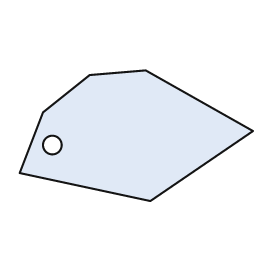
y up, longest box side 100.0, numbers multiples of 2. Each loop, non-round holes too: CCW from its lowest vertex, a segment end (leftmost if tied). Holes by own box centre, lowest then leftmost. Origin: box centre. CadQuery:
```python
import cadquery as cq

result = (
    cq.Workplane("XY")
    .moveTo(6.0, -28.0)
    .lineTo(50.0, 2.0)
    .lineTo(4.0, 28.0)
    .lineTo(-20.0, 26.0)
    .lineTo(-40.0, 10.0)
    .lineTo(-50.0, -16.0)
    .close()
    .moveTo(-36.0, -4.0)
    .circle(4.0)
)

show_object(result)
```